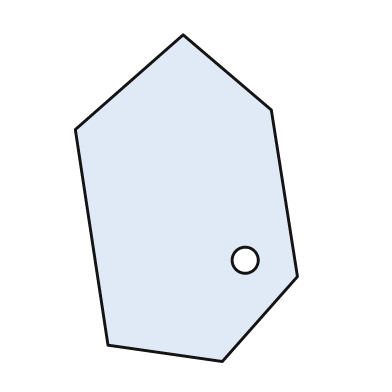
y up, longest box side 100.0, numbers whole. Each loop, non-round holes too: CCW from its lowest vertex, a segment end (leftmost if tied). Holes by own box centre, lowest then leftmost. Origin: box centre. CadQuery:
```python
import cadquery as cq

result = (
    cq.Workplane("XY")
    .moveTo(11.0, -50.0)
    .lineTo(34.0, -24.0)
    .lineTo(26.0, 27.0)
    .lineTo(-1.0, 50.0)
    .lineTo(-34.0, 21.0)
    .lineTo(-24.0, -45.0)
    .close()
    .moveTo(18.0, -19.0)
    .circle(4.0)
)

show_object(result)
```